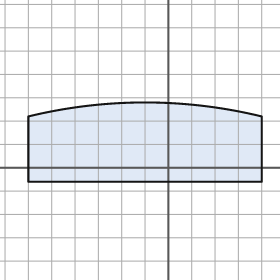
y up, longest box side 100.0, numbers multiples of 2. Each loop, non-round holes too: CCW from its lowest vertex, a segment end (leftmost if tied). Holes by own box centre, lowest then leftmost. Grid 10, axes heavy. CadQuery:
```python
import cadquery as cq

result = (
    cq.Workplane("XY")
    .moveTo(-60.0, -6.0)
    .lineTo(40.0, -6.0)
    .lineTo(40.0, 22.0)
    .threePointArc((-10.0, 28.0), (-60.0, 22.0))
    .close()
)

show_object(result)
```